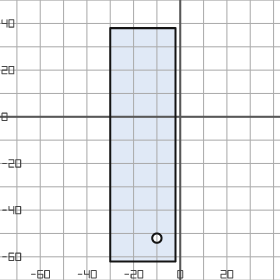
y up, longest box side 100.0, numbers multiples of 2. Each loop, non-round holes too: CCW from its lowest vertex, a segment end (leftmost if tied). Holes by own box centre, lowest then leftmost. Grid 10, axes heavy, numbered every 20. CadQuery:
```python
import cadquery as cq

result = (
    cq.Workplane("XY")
    .moveTo(-30.0, -62.0)
    .lineTo(-2.0, -62.0)
    .lineTo(-2.0, 38.0)
    .lineTo(-30.0, 38.0)
    .close()
    .moveTo(-10.0, -52.0)
    .circle(2.0)
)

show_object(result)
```